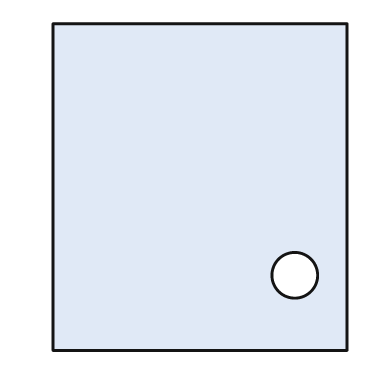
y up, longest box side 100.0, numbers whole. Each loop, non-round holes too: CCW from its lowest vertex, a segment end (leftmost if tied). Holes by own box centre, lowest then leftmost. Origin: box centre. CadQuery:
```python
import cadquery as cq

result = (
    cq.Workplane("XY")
    .moveTo(-45.0, -50.0)
    .lineTo(45.0, -50.0)
    .lineTo(45.0, 50.0)
    .lineTo(-45.0, 50.0)
    .close()
    .moveTo(29.0, -27.0)
    .circle(7.0)
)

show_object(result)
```